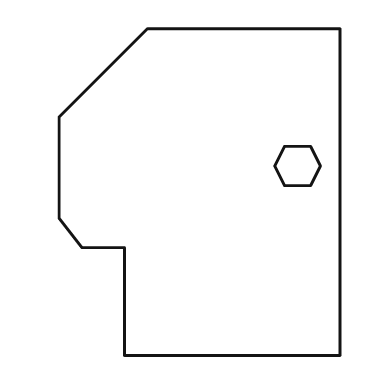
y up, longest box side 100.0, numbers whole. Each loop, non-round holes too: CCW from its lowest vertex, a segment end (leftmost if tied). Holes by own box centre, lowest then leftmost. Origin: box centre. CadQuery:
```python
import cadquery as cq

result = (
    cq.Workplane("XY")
    .moveTo(-23.0, -50.0)
    .lineTo(43.0, -50.0)
    .lineTo(43.0, 50.0)
    .lineTo(-16.0, 50.0)
    .lineTo(-43.0, 23.0)
    .lineTo(-43.0, -8.0)
    .lineTo(-36.0, -17.0)
    .lineTo(-23.0, -17.0)
    .close()
    .moveTo(26.0, 2.0)
    .lineTo(34.0, 2.0)
    .lineTo(37.0, 8.0)
    .lineTo(34.0, 14.0)
    .lineTo(26.0, 14.0)
    .lineTo(23.0, 8.0)
    .close()
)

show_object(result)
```